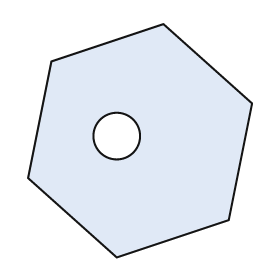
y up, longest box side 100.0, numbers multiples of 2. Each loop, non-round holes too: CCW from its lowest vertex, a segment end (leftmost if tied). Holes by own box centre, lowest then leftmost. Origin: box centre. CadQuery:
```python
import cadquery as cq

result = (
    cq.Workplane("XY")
    .moveTo(-10.0, -50.0)
    .lineTo(38.0, -34.0)
    .lineTo(48.0, 16.0)
    .lineTo(10.0, 50.0)
    .lineTo(-38.0, 34.0)
    .lineTo(-48.0, -16.0)
    .close()
    .moveTo(-10.0, 2.0)
    .circle(10.0)
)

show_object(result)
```